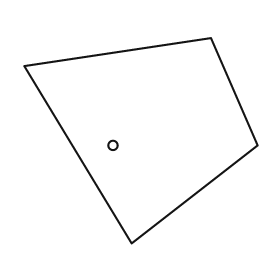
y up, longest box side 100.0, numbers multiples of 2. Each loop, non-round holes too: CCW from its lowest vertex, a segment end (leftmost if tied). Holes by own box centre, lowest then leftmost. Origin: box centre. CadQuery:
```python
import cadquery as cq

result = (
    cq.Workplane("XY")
    .moveTo(-4.0, -44.0)
    .lineTo(50.0, -2.0)
    .lineTo(30.0, 44.0)
    .lineTo(-50.0, 32.0)
    .close()
    .moveTo(-12.0, -2.0)
    .circle(2.0)
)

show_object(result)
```